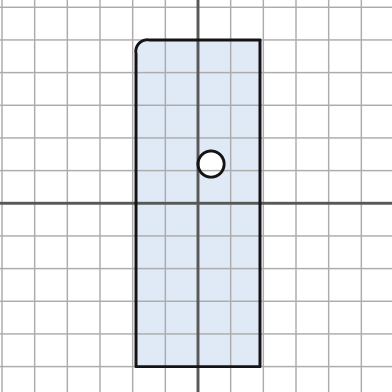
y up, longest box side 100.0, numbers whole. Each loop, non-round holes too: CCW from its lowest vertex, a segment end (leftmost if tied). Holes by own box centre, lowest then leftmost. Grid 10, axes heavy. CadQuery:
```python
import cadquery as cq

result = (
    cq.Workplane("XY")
    .moveTo(-19.0, -50.0)
    .lineTo(19.0, -50.0)
    .lineTo(19.0, 50.0)
    .lineTo(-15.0, 50.0)
    .threePointArc((-18.0, 49.0), (-19.0, 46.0))
    .close()
    .moveTo(4.0, 12.0)
    .circle(4.0)
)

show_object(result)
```